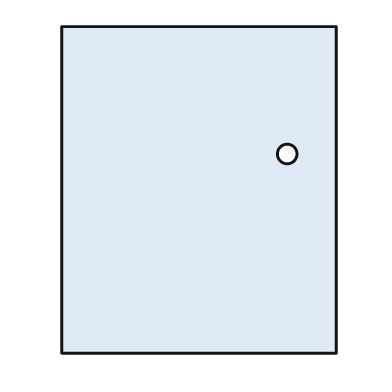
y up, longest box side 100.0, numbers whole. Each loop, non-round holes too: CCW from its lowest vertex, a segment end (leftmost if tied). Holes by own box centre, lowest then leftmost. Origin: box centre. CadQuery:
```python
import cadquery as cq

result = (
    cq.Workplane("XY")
    .moveTo(-42.0, -50.0)
    .lineTo(42.0, -50.0)
    .lineTo(42.0, 50.0)
    .lineTo(-42.0, 50.0)
    .close()
    .moveTo(27.0, 11.0)
    .circle(3.0)
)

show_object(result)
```